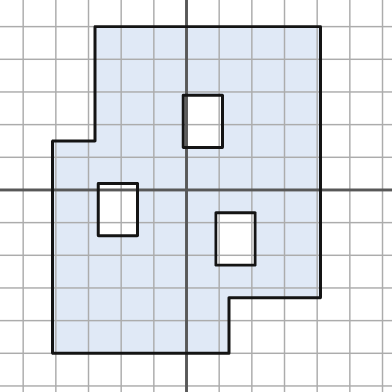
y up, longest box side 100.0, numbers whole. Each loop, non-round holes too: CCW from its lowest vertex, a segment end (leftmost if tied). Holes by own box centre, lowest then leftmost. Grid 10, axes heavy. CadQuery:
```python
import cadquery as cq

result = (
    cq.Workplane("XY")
    .moveTo(-41.0, -50.0)
    .lineTo(13.0, -50.0)
    .lineTo(13.0, -33.0)
    .lineTo(41.0, -33.0)
    .lineTo(41.0, 50.0)
    .lineTo(-28.0, 50.0)
    .lineTo(-28.0, 15.0)
    .lineTo(-41.0, 15.0)
    .close()
    .moveTo(9.0, -23.0)
    .lineTo(21.0, -23.0)
    .lineTo(21.0, -7.0)
    .lineTo(9.0, -7.0)
    .close()
    .moveTo(-27.0, -14.0)
    .lineTo(-15.0, -14.0)
    .lineTo(-15.0, 2.0)
    .lineTo(-27.0, 2.0)
    .close()
    .moveTo(-1.0, 13.0)
    .lineTo(11.0, 13.0)
    .lineTo(11.0, 29.0)
    .lineTo(-1.0, 29.0)
    .close()
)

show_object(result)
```